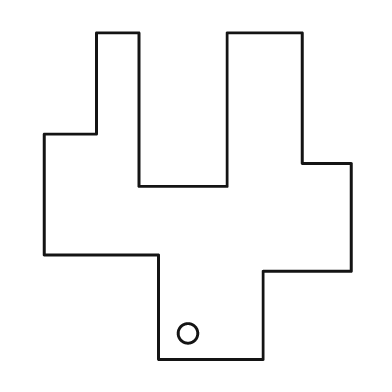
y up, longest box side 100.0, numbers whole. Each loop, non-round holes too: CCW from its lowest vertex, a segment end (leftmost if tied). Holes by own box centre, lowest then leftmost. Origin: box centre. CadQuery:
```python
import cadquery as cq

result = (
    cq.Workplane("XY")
    .moveTo(-12.0, -50.0)
    .lineTo(20.0, -50.0)
    .lineTo(20.0, -23.0)
    .lineTo(47.0, -23.0)
    .lineTo(47.0, 10.0)
    .lineTo(32.0, 10.0)
    .lineTo(32.0, 50.0)
    .lineTo(9.0, 50.0)
    .lineTo(9.0, 3.0)
    .lineTo(-18.0, 3.0)
    .lineTo(-18.0, 50.0)
    .lineTo(-31.0, 50.0)
    .lineTo(-31.0, 19.0)
    .lineTo(-47.0, 19.0)
    .lineTo(-47.0, -18.0)
    .lineTo(-12.0, -18.0)
    .close()
    .moveTo(-3.0, -42.0)
    .circle(3.0)
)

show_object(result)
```